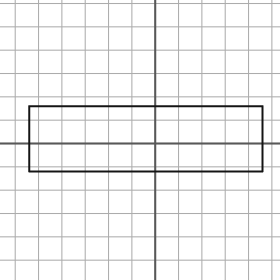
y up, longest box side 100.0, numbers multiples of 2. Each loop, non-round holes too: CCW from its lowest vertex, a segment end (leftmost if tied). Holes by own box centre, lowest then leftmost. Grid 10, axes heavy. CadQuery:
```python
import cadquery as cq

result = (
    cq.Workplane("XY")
    .moveTo(-54.0, -12.0)
    .lineTo(46.0, -12.0)
    .lineTo(46.0, 16.0)
    .lineTo(-54.0, 16.0)
    .close()
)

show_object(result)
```